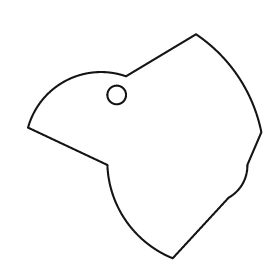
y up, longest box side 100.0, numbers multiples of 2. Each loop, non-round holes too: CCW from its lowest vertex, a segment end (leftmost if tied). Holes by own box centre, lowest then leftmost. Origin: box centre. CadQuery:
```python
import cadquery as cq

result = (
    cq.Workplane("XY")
    .moveTo(12.0, -48.0)
    .lineTo(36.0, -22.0)
    .threePointArc((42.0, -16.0), (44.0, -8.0))
    .lineTo(50.0, 6.0)
    .threePointArc((40.0, 30.0), (22.0, 48.0))
    .lineTo(-8.0, 30.0)
    .threePointArc((-34.0, 28.0), (-50.0, 8.0))
    .lineTo(-16.0, -8.0)
    .threePointArc((-8.0, -32.0), (12.0, -48.0))
    .close()
    .moveTo(-12.0, 22.0)
    .circle(4.0)
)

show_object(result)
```